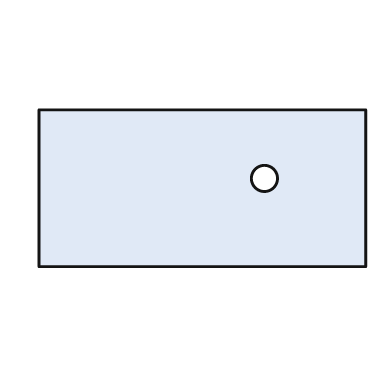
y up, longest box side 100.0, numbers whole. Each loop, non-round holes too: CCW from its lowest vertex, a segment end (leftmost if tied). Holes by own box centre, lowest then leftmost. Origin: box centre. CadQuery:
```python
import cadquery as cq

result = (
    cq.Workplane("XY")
    .moveTo(-50.0, -24.0)
    .lineTo(50.0, -24.0)
    .lineTo(50.0, 24.0)
    .lineTo(-50.0, 24.0)
    .close()
    .moveTo(19.0, 3.0)
    .circle(4.0)
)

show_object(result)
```